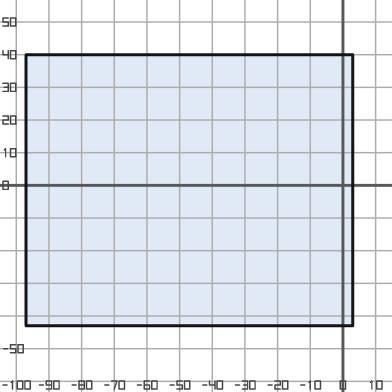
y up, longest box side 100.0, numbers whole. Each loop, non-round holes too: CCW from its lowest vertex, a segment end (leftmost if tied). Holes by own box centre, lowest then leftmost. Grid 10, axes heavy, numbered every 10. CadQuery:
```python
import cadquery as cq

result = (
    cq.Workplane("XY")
    .moveTo(-97.0, -43.0)
    .lineTo(3.0, -43.0)
    .lineTo(3.0, 40.0)
    .lineTo(-97.0, 40.0)
    .close()
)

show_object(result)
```